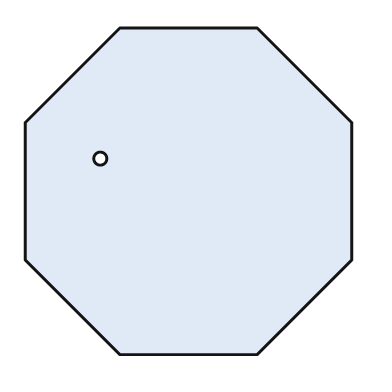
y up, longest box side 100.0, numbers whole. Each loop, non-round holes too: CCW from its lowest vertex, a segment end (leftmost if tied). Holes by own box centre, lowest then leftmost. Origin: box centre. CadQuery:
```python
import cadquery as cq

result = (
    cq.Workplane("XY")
    .moveTo(-21.0, -50.0)
    .lineTo(21.0, -50.0)
    .lineTo(50.0, -21.0)
    .lineTo(50.0, 21.0)
    .lineTo(21.0, 50.0)
    .lineTo(-21.0, 50.0)
    .lineTo(-50.0, 21.0)
    .lineTo(-50.0, -21.0)
    .close()
    .moveTo(-27.0, 10.0)
    .circle(2.0)
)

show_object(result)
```